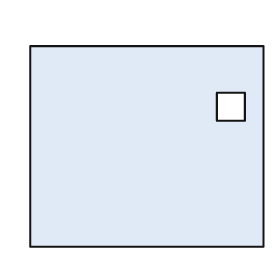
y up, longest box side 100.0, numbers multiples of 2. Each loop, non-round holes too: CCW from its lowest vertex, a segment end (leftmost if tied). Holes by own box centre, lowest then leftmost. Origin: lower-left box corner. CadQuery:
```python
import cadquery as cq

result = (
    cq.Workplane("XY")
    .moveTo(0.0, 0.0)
    .lineTo(100.0, 0.0)
    .lineTo(100.0, 86.0)
    .lineTo(0.0, 86.0)
    .close()
    .moveTo(80.0, 54.0)
    .lineTo(92.0, 54.0)
    .lineTo(92.0, 66.0)
    .lineTo(80.0, 66.0)
    .close()
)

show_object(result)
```